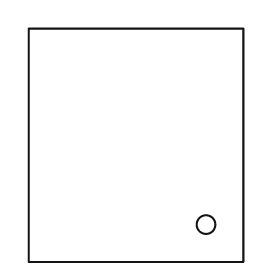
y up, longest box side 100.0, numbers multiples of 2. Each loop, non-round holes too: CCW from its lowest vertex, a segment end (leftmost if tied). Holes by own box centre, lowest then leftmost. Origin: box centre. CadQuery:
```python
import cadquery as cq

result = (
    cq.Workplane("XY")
    .moveTo(-46.0, -50.0)
    .lineTo(46.0, -50.0)
    .lineTo(46.0, 50.0)
    .lineTo(-46.0, 50.0)
    .close()
    .moveTo(30.0, -34.0)
    .circle(4.0)
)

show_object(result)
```